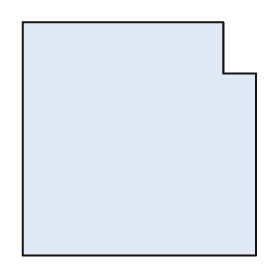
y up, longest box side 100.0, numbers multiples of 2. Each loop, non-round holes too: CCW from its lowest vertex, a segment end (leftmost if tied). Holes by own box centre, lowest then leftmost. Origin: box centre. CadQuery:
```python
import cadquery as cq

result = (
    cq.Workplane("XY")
    .moveTo(-50.0, -50.0)
    .lineTo(50.0, -50.0)
    .lineTo(50.0, 28.0)
    .lineTo(36.0, 28.0)
    .lineTo(36.0, 50.0)
    .lineTo(-50.0, 50.0)
    .close()
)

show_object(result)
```